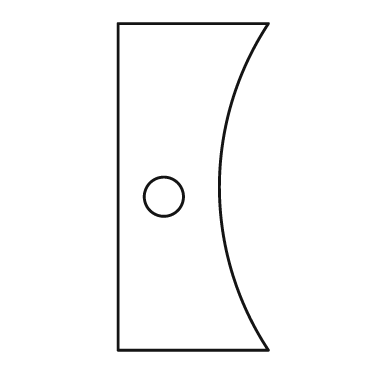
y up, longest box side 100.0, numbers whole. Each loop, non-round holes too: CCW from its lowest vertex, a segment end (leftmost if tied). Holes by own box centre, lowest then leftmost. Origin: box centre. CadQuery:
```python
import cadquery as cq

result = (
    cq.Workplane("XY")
    .moveTo(-23.0, -50.0)
    .lineTo(23.0, -50.0)
    .threePointArc((8.0, 0.0), (23.0, 50.0))
    .lineTo(-23.0, 50.0)
    .close()
    .moveTo(-9.0, -3.0)
    .circle(6.0)
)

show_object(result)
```